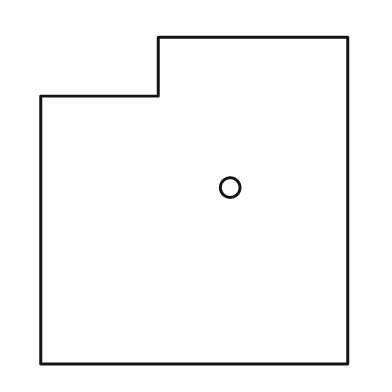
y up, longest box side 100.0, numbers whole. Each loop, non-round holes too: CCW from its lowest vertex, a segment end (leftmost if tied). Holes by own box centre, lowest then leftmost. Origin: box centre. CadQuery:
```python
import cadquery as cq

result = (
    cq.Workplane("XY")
    .moveTo(-47.0, -50.0)
    .lineTo(47.0, -50.0)
    .lineTo(47.0, 50.0)
    .lineTo(-11.0, 50.0)
    .lineTo(-11.0, 32.0)
    .lineTo(-47.0, 32.0)
    .close()
    .moveTo(11.0, 4.0)
    .circle(3.0)
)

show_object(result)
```